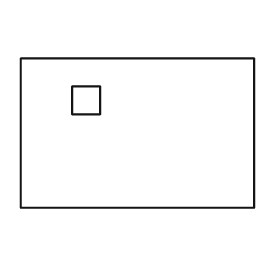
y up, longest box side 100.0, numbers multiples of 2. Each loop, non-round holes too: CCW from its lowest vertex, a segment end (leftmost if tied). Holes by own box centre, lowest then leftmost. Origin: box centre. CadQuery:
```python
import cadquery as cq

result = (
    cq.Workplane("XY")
    .moveTo(-50.0, -32.0)
    .lineTo(50.0, -32.0)
    .lineTo(50.0, 32.0)
    .lineTo(-50.0, 32.0)
    .close()
    .moveTo(-28.0, 8.0)
    .lineTo(-16.0, 8.0)
    .lineTo(-16.0, 20.0)
    .lineTo(-28.0, 20.0)
    .close()
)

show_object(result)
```